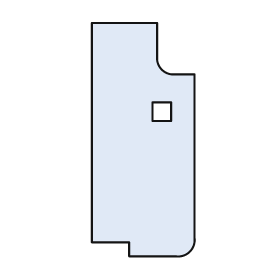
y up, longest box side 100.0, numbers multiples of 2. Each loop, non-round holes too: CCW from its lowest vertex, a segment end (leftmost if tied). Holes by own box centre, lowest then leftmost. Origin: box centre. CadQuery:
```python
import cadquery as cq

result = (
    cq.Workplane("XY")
    .moveTo(-6.0, -50.0)
    .lineTo(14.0, -50.0)
    .threePointArc((20.0, -48.0), (22.0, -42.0))
    .lineTo(22.0, 28.0)
    .lineTo(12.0, 28.0)
    .threePointArc((8.0, 30.0), (6.0, 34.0))
    .lineTo(6.0, 50.0)
    .lineTo(-22.0, 50.0)
    .lineTo(-22.0, -44.0)
    .lineTo(-6.0, -44.0)
    .close()
    .moveTo(4.0, 8.0)
    .lineTo(12.0, 8.0)
    .lineTo(12.0, 16.0)
    .lineTo(4.0, 16.0)
    .close()
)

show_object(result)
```